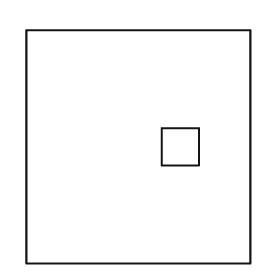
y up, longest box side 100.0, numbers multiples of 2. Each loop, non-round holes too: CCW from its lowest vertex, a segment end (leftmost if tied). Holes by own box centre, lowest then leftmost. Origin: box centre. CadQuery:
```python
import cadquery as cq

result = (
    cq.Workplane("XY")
    .moveTo(-48.0, -50.0)
    .lineTo(48.0, -50.0)
    .lineTo(48.0, 50.0)
    .lineTo(-48.0, 50.0)
    .close()
    .moveTo(10.0, -8.0)
    .lineTo(26.0, -8.0)
    .lineTo(26.0, 8.0)
    .lineTo(10.0, 8.0)
    .close()
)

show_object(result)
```